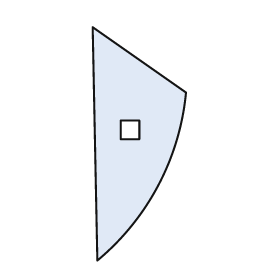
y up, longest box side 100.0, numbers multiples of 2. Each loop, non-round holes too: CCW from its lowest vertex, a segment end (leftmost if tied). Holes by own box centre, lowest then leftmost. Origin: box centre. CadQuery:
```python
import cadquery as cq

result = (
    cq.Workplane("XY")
    .moveTo(-18.0, -50.0)
    .threePointArc((8.0, -18.0), (20.0, 22.0))
    .lineTo(-20.0, 50.0)
    .close()
    .moveTo(-8.0, 2.0)
    .lineTo(0.0, 2.0)
    .lineTo(0.0, 10.0)
    .lineTo(-8.0, 10.0)
    .close()
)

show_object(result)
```